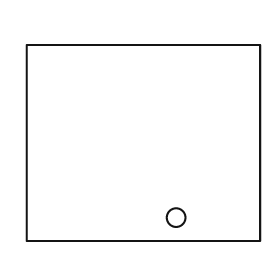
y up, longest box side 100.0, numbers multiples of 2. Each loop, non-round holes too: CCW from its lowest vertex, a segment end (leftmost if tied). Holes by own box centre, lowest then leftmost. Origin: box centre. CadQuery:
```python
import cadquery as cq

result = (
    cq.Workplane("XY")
    .moveTo(-50.0, -42.0)
    .lineTo(50.0, -42.0)
    .lineTo(50.0, 42.0)
    .lineTo(-50.0, 42.0)
    .close()
    .moveTo(14.0, -32.0)
    .circle(4.0)
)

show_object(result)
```